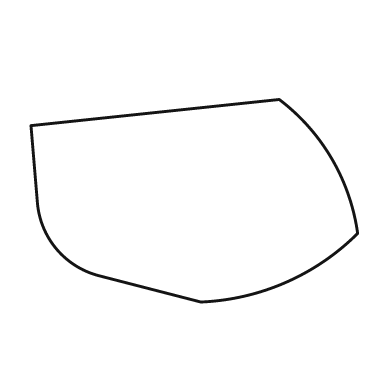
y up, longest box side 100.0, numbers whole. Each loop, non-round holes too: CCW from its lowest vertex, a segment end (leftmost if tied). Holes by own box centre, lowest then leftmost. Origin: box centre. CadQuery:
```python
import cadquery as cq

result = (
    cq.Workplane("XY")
    .moveTo(2.0, -31.0)
    .threePointArc((28.0, -25.0), (50.0, -10.0))
    .threePointArc((42.0, 13.0), (26.0, 31.0))
    .lineTo(-50.0, 23.0)
    .lineTo(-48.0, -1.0)
    .threePointArc((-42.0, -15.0), (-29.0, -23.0))
    .close()
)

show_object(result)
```